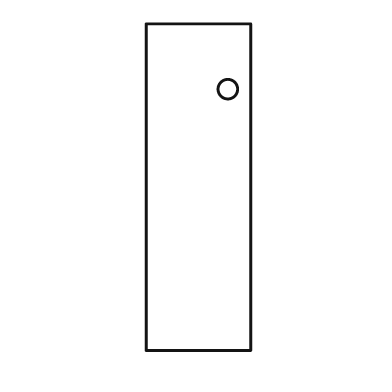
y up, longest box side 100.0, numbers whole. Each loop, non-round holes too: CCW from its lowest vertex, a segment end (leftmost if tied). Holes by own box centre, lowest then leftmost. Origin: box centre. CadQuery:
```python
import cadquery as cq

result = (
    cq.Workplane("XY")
    .moveTo(-16.0, -50.0)
    .lineTo(16.0, -50.0)
    .lineTo(16.0, 50.0)
    .lineTo(-16.0, 50.0)
    .close()
    .moveTo(9.0, 30.0)
    .circle(3.0)
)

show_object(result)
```